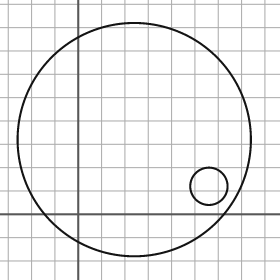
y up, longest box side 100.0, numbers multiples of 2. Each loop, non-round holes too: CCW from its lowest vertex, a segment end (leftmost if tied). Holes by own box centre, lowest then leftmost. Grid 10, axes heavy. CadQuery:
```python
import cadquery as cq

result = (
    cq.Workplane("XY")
    .moveTo(24.0, 32.0)
    .circle(50.0)
    .moveTo(56.0, 12.0)
    .circle(8.0)
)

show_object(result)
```